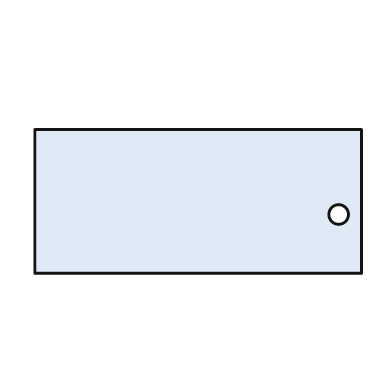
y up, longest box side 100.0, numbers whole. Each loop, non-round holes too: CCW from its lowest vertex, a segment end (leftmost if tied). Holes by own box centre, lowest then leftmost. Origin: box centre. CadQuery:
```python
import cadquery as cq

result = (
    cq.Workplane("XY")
    .moveTo(-50.0, -22.0)
    .lineTo(50.0, -22.0)
    .lineTo(50.0, 22.0)
    .lineTo(-50.0, 22.0)
    .close()
    .moveTo(43.0, -4.0)
    .circle(3.0)
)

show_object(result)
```